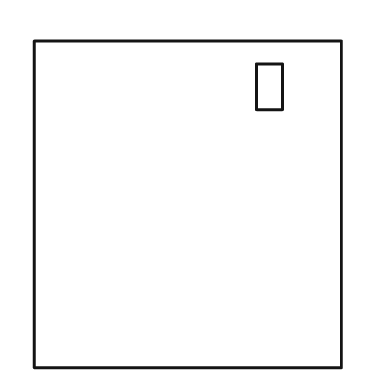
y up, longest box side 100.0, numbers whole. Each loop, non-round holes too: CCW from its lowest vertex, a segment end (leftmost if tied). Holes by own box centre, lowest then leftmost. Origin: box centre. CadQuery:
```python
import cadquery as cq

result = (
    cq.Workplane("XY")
    .moveTo(-47.0, -50.0)
    .lineTo(47.0, -50.0)
    .lineTo(47.0, 50.0)
    .lineTo(-47.0, 50.0)
    .close()
    .moveTo(21.0, 29.0)
    .lineTo(29.0, 29.0)
    .lineTo(29.0, 43.0)
    .lineTo(21.0, 43.0)
    .close()
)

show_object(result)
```